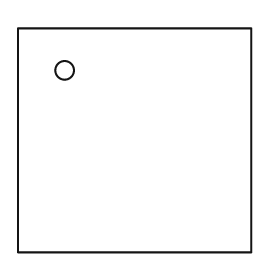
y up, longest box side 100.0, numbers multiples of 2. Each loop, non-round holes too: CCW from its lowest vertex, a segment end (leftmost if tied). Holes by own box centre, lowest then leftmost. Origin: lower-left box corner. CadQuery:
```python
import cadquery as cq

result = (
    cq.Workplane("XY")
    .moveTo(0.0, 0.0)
    .lineTo(100.0, 0.0)
    .lineTo(100.0, 96.0)
    .lineTo(0.0, 96.0)
    .close()
    .moveTo(20.0, 78.0)
    .circle(4.0)
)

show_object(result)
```